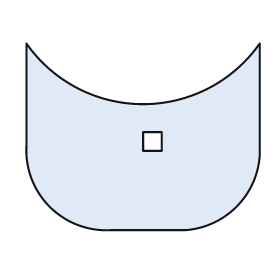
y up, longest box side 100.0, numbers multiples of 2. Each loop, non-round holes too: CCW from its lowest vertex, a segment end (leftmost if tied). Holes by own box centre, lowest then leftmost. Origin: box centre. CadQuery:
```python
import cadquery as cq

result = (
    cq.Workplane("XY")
    .moveTo(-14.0, -40.0)
    .lineTo(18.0, -40.0)
    .threePointArc((40.0, -30.0), (50.0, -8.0))
    .lineTo(50.0, 40.0)
    .threePointArc((0.0, 14.0), (-50.0, 40.0))
    .lineTo(-50.0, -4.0)
    .threePointArc((-40.0, -30.0), (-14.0, -40.0))
    .close()
    .moveTo(0.0, -6.0)
    .lineTo(8.0, -6.0)
    .lineTo(8.0, 2.0)
    .lineTo(0.0, 2.0)
    .close()
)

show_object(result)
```